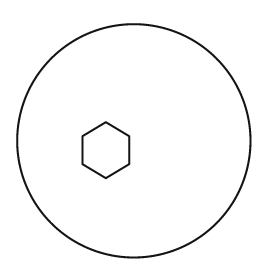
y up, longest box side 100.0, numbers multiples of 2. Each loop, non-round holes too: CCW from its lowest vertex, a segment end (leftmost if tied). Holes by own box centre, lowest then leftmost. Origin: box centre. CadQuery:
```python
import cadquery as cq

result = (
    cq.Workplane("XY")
    .moveTo(0.0, 0.0)
    .circle(50.0)
    .moveTo(-12.0, -16.0)
    .lineTo(-2.0, -10.0)
    .lineTo(-2.0, 2.0)
    .lineTo(-12.0, 8.0)
    .lineTo(-22.0, 2.0)
    .lineTo(-22.0, -10.0)
    .close()
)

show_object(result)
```